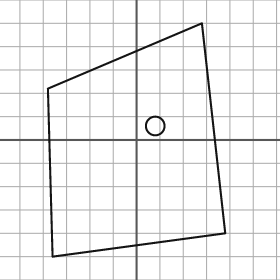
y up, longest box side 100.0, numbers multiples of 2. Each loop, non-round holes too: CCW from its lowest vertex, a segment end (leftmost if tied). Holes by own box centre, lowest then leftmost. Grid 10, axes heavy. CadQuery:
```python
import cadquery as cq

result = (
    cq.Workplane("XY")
    .moveTo(-36.0, -50.0)
    .lineTo(38.0, -40.0)
    .lineTo(28.0, 50.0)
    .lineTo(-38.0, 22.0)
    .close()
    .moveTo(8.0, 6.0)
    .circle(4.0)
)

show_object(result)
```